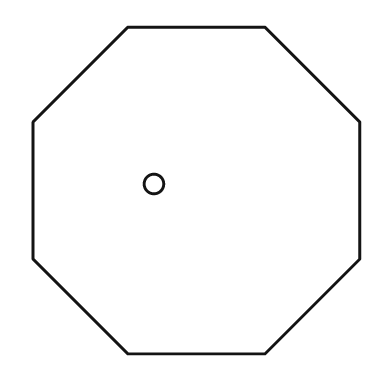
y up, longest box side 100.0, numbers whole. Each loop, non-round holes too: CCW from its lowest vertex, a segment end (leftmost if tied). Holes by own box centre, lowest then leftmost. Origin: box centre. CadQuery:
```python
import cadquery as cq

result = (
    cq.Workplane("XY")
    .moveTo(-21.0, -50.0)
    .lineTo(21.0, -50.0)
    .lineTo(50.0, -21.0)
    .lineTo(50.0, 21.0)
    .lineTo(21.0, 50.0)
    .lineTo(-21.0, 50.0)
    .lineTo(-50.0, 21.0)
    .lineTo(-50.0, -21.0)
    .close()
    .moveTo(-13.0, 2.0)
    .circle(3.0)
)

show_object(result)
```